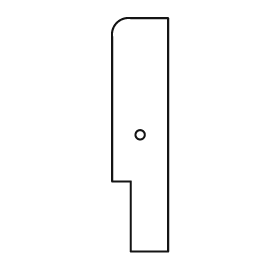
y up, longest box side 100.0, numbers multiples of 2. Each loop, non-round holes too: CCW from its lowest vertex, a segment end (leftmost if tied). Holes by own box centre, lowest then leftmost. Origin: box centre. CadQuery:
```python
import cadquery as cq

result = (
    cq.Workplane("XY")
    .moveTo(-4.0, -50.0)
    .lineTo(12.0, -50.0)
    .lineTo(12.0, 50.0)
    .lineTo(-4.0, 50.0)
    .threePointArc((-10.0, 48.0), (-12.0, 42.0))
    .lineTo(-12.0, -20.0)
    .lineTo(-4.0, -20.0)
    .close()
    .moveTo(0.0, 0.0)
    .circle(2.0)
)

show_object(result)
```